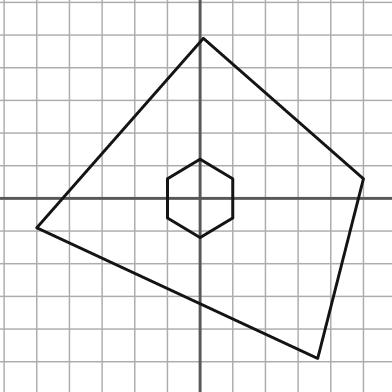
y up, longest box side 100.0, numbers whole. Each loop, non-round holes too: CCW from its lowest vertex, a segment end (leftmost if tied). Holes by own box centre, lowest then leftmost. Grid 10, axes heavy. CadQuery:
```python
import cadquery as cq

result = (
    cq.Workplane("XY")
    .moveTo(36.0, -49.0)
    .lineTo(50.0, 6.0)
    .lineTo(1.0, 49.0)
    .lineTo(-50.0, -9.0)
    .close()
    .moveTo(0.0, -12.0)
    .lineTo(10.0, -6.0)
    .lineTo(10.0, 6.0)
    .lineTo(0.0, 12.0)
    .lineTo(-10.0, 6.0)
    .lineTo(-10.0, -6.0)
    .close()
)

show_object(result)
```